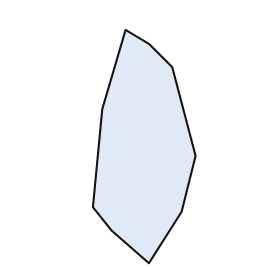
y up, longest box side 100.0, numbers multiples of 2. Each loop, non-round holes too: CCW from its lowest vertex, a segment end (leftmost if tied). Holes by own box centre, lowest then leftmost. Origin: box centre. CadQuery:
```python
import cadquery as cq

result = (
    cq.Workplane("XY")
    .moveTo(2.0, -50.0)
    .lineTo(16.0, -28.0)
    .lineTo(22.0, -4.0)
    .lineTo(12.0, 34.0)
    .lineTo(2.0, 44.0)
    .lineTo(-8.0, 50.0)
    .lineTo(-18.0, 16.0)
    .lineTo(-22.0, -26.0)
    .lineTo(-14.0, -36.0)
    .close()
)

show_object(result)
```